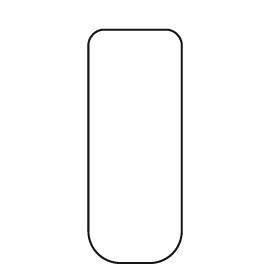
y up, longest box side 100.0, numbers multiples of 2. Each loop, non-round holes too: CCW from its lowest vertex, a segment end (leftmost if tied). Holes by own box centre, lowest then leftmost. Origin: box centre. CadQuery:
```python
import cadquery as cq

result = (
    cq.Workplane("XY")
    .moveTo(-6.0, -50.0)
    .lineTo(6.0, -50.0)
    .threePointArc((16.0, -46.0), (20.0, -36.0))
    .lineTo(20.0, 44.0)
    .threePointArc((18.0, 48.0), (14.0, 50.0))
    .lineTo(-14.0, 50.0)
    .threePointArc((-18.0, 48.0), (-20.0, 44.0))
    .lineTo(-20.0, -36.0)
    .threePointArc((-16.0, -46.0), (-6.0, -50.0))
    .close()
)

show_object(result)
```